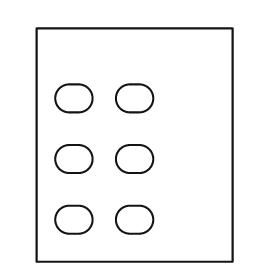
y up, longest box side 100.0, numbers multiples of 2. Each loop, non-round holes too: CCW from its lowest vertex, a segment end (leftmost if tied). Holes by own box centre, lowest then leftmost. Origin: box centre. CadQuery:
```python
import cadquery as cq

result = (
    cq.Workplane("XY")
    .moveTo(-42.0, -50.0)
    .lineTo(42.0, -50.0)
    .lineTo(42.0, 50.0)
    .lineTo(-42.0, 50.0)
    .close()
    .moveTo(-28.0, -38.0)
    .lineTo(-24.0, -38.0)
    .threePointArc((-18.0, -32.0), (-24.0, -26.0))
    .lineTo(-28.0, -26.0)
    .threePointArc((-34.0, -32.0), (-28.0, -38.0))
    .close()
    .moveTo(-2.0, -38.0)
    .lineTo(2.0, -38.0)
    .threePointArc((8.0, -32.0), (2.0, -26.0))
    .lineTo(-2.0, -26.0)
    .threePointArc((-8.0, -32.0), (-2.0, -38.0))
    .close()
    .moveTo(-28.0, -12.0)
    .lineTo(-24.0, -12.0)
    .threePointArc((-18.0, -6.0), (-24.0, 0.0))
    .lineTo(-28.0, 0.0)
    .threePointArc((-34.0, -6.0), (-28.0, -12.0))
    .close()
    .moveTo(-2.0, -12.0)
    .lineTo(2.0, -12.0)
    .threePointArc((8.0, -6.0), (2.0, 0.0))
    .lineTo(-2.0, 0.0)
    .threePointArc((-8.0, -6.0), (-2.0, -12.0))
    .close()
    .moveTo(-28.0, 14.0)
    .lineTo(-24.0, 14.0)
    .threePointArc((-18.0, 20.0), (-24.0, 26.0))
    .lineTo(-28.0, 26.0)
    .threePointArc((-34.0, 20.0), (-28.0, 14.0))
    .close()
    .moveTo(-2.0, 14.0)
    .lineTo(2.0, 14.0)
    .threePointArc((8.0, 20.0), (2.0, 26.0))
    .lineTo(-2.0, 26.0)
    .threePointArc((-8.0, 20.0), (-2.0, 14.0))
    .close()
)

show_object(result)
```